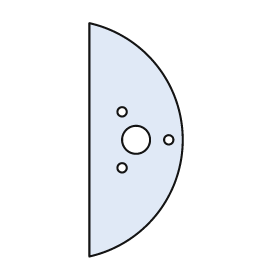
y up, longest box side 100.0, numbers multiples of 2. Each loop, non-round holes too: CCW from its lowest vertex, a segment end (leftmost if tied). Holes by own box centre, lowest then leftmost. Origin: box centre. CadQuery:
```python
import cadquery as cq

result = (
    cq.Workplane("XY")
    .moveTo(-20.0, -50.0)
    .threePointArc((20.0, 0.0), (-20.0, 50.0))
    .close()
    .moveTo(-6.0, -12.0)
    .circle(2.0)
    .moveTo(0.0, 0.0)
    .circle(6.0)
    .moveTo(14.0, 0.0)
    .circle(2.0)
    .moveTo(-6.0, 12.0)
    .circle(2.0)
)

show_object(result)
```